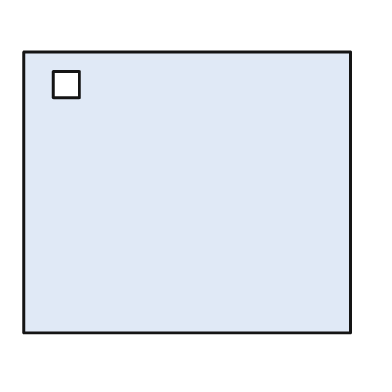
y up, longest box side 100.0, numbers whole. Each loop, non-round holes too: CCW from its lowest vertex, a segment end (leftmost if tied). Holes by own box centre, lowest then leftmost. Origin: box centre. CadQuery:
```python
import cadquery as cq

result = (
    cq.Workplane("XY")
    .moveTo(-50.0, -43.0)
    .lineTo(50.0, -43.0)
    .lineTo(50.0, 43.0)
    .lineTo(-50.0, 43.0)
    .close()
    .moveTo(-41.0, 29.0)
    .lineTo(-33.0, 29.0)
    .lineTo(-33.0, 37.0)
    .lineTo(-41.0, 37.0)
    .close()
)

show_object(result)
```